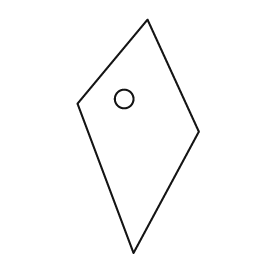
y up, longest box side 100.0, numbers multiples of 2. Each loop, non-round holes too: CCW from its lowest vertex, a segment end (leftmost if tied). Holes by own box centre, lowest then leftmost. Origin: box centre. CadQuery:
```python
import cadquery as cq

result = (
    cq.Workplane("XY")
    .moveTo(-2.0, -50.0)
    .lineTo(26.0, 2.0)
    .lineTo(4.0, 50.0)
    .lineTo(-26.0, 14.0)
    .close()
    .moveTo(-6.0, 16.0)
    .circle(4.0)
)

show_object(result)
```